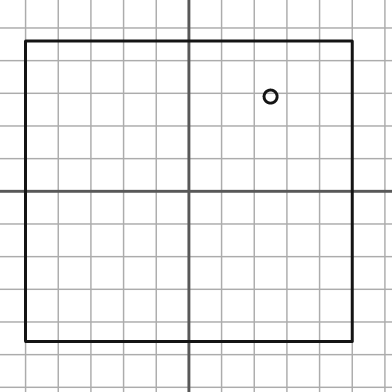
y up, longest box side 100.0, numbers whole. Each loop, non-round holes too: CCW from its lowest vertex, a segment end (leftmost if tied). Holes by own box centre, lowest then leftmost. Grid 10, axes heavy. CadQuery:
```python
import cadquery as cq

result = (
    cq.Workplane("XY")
    .moveTo(-50.0, -46.0)
    .lineTo(50.0, -46.0)
    .lineTo(50.0, 46.0)
    .lineTo(-50.0, 46.0)
    .close()
    .moveTo(25.0, 29.0)
    .circle(2.0)
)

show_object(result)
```